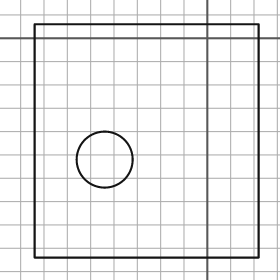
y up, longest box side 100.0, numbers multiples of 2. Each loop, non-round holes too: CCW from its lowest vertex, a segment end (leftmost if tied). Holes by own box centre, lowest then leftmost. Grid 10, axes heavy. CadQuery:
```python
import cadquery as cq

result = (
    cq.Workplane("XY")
    .moveTo(-74.0, -94.0)
    .lineTo(22.0, -94.0)
    .lineTo(22.0, 6.0)
    .lineTo(-74.0, 6.0)
    .close()
    .moveTo(-44.0, -52.0)
    .circle(12.0)
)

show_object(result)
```